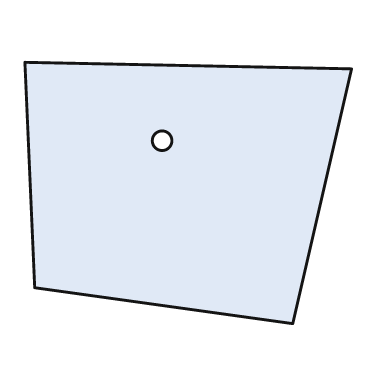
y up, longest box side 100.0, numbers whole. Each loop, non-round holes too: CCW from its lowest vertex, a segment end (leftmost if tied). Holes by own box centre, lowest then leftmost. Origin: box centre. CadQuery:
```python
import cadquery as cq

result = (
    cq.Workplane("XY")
    .moveTo(32.0, -40.0)
    .lineTo(50.0, 38.0)
    .lineTo(-50.0, 40.0)
    .lineTo(-47.0, -29.0)
    .close()
    .moveTo(-8.0, 16.0)
    .circle(3.0)
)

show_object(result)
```